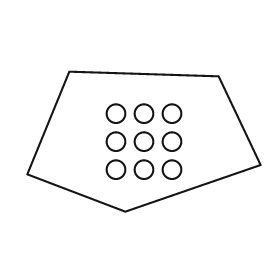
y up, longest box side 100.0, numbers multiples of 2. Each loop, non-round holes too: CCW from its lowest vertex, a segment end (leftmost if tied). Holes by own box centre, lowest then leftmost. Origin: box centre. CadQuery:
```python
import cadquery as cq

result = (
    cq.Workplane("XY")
    .moveTo(-8.0, -30.0)
    .lineTo(50.0, -10.0)
    .lineTo(32.0, 28.0)
    .lineTo(-32.0, 30.0)
    .lineTo(-50.0, -14.0)
    .close()
    .moveTo(-12.0, -12.0)
    .circle(4.0)
    .moveTo(0.0, -12.0)
    .circle(4.0)
    .moveTo(12.0, -12.0)
    .circle(4.0)
    .moveTo(-12.0, 0.0)
    .circle(4.0)
    .moveTo(0.0, 0.0)
    .circle(4.0)
    .moveTo(12.0, 0.0)
    .circle(4.0)
    .moveTo(-12.0, 12.0)
    .circle(4.0)
    .moveTo(0.0, 12.0)
    .circle(4.0)
    .moveTo(12.0, 12.0)
    .circle(4.0)
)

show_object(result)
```